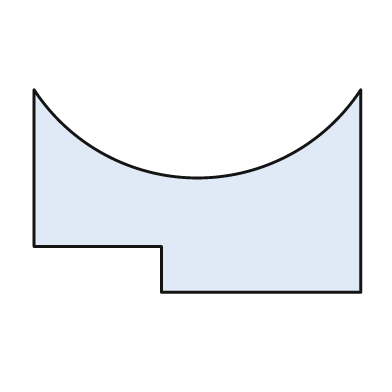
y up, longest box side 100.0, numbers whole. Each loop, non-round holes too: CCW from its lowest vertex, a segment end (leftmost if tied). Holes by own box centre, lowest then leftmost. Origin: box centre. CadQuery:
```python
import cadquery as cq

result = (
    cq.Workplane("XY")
    .moveTo(-11.0, -31.0)
    .lineTo(50.0, -31.0)
    .lineTo(50.0, 31.0)
    .threePointArc((0.0, 4.0), (-50.0, 31.0))
    .lineTo(-50.0, -17.0)
    .lineTo(-11.0, -17.0)
    .close()
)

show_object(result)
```